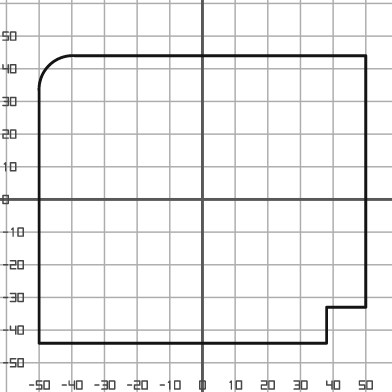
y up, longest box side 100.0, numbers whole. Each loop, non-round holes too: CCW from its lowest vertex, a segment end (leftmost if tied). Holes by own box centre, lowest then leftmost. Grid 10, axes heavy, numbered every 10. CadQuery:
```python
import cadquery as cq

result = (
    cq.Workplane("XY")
    .moveTo(-50.0, -44.0)
    .lineTo(38.0, -44.0)
    .lineTo(38.0, -33.0)
    .lineTo(50.0, -33.0)
    .lineTo(50.0, 44.0)
    .lineTo(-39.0, 44.0)
    .threePointArc((-47.0, 41.0), (-50.0, 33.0))
    .close()
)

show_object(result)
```